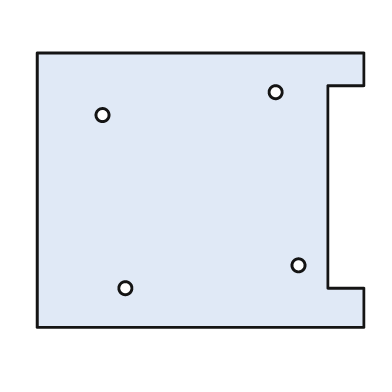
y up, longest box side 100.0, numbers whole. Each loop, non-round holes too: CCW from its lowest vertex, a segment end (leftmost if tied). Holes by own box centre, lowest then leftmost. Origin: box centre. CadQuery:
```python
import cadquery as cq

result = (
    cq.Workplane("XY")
    .moveTo(-50.0, -42.0)
    .lineTo(50.0, -42.0)
    .lineTo(50.0, -30.0)
    .lineTo(39.0, -30.0)
    .lineTo(39.0, 32.0)
    .lineTo(50.0, 32.0)
    .lineTo(50.0, 42.0)
    .lineTo(-50.0, 42.0)
    .close()
    .moveTo(-23.0, -30.0)
    .circle(2.0)
    .moveTo(30.0, -23.0)
    .circle(2.0)
    .moveTo(-30.0, 23.0)
    .circle(2.0)
    .moveTo(23.0, 30.0)
    .circle(2.0)
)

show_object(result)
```